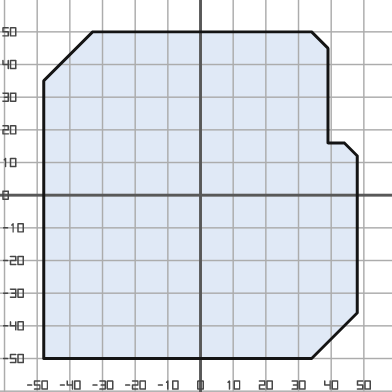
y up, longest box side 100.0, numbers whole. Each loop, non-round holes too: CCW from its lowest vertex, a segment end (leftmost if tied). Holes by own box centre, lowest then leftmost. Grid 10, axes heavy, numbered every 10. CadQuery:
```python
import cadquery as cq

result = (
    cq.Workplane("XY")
    .moveTo(-48.0, -50.0)
    .lineTo(34.0, -50.0)
    .lineTo(48.0, -36.0)
    .lineTo(48.0, 12.0)
    .lineTo(44.0, 16.0)
    .lineTo(39.0, 16.0)
    .lineTo(39.0, 45.0)
    .lineTo(34.0, 50.0)
    .lineTo(-33.0, 50.0)
    .lineTo(-48.0, 35.0)
    .close()
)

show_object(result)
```